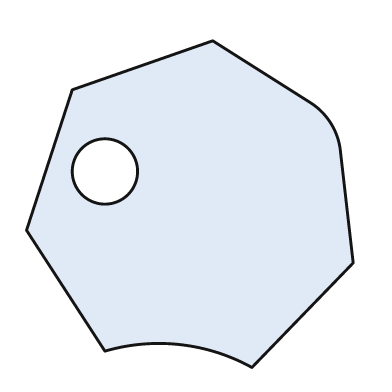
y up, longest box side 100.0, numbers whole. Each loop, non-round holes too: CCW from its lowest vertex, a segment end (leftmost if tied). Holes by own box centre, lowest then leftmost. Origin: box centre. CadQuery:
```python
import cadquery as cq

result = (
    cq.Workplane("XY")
    .moveTo(19.0, -50.0)
    .lineTo(50.0, -18.0)
    .lineTo(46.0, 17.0)
    .threePointArc((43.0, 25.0), (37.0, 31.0))
    .lineTo(7.0, 50.0)
    .lineTo(-36.0, 35.0)
    .lineTo(-50.0, -8.0)
    .lineTo(-26.0, -45.0)
    .threePointArc((-3.0, -43.0), (19.0, -50.0))
    .close()
    .moveTo(-26.0, 10.0)
    .circle(10.0)
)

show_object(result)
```